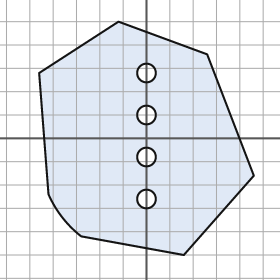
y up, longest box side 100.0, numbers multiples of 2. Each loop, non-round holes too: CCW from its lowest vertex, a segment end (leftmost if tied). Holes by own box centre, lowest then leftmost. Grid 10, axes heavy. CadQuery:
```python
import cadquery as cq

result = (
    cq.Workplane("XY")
    .moveTo(16.0, -50.0)
    .lineTo(46.0, -16.0)
    .lineTo(26.0, 36.0)
    .lineTo(-12.0, 50.0)
    .lineTo(-46.0, 28.0)
    .lineTo(-42.0, -24.0)
    .threePointArc((-36.0, -34.0), (-28.0, -42.0))
    .close()
    .moveTo(0.0, -26.0)
    .circle(4.0)
    .moveTo(0.0, -8.0)
    .circle(4.0)
    .moveTo(0.0, 10.0)
    .circle(4.0)
    .moveTo(0.0, 28.0)
    .circle(4.0)
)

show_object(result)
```